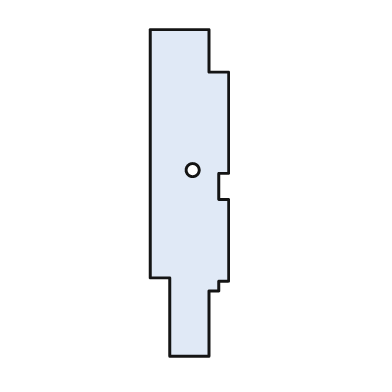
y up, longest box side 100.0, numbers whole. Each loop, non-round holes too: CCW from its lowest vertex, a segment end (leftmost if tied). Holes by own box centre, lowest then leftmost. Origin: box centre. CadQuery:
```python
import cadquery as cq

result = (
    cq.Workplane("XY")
    .moveTo(-6.0, -50.0)
    .lineTo(6.0, -50.0)
    .lineTo(6.0, -30.0)
    .lineTo(9.0, -30.0)
    .lineTo(9.0, -27.0)
    .lineTo(12.0, -27.0)
    .lineTo(12.0, -2.0)
    .lineTo(9.0, -2.0)
    .lineTo(9.0, 6.0)
    .lineTo(12.0, 6.0)
    .lineTo(12.0, 37.0)
    .lineTo(6.0, 37.0)
    .lineTo(6.0, 50.0)
    .lineTo(-12.0, 50.0)
    .lineTo(-12.0, -26.0)
    .lineTo(-6.0, -26.0)
    .close()
    .moveTo(1.0, 7.0)
    .circle(2.0)
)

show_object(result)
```